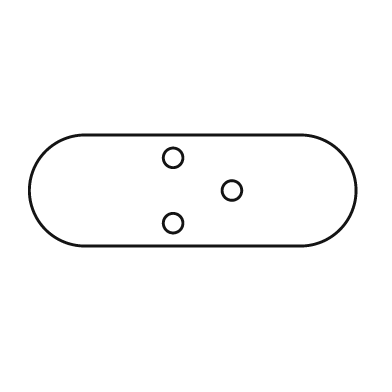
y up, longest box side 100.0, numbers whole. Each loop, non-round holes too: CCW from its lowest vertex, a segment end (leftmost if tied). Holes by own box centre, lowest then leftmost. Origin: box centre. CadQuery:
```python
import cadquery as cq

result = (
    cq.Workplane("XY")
    .moveTo(-33.0, -17.0)
    .lineTo(33.0, -17.0)
    .threePointArc((50.0, 0.0), (33.0, 17.0))
    .lineTo(-33.0, 17.0)
    .threePointArc((-50.0, 0.0), (-33.0, -17.0))
    .close()
    .moveTo(-6.0, -10.0)
    .circle(3.0)
    .moveTo(12.0, 0.0)
    .circle(3.0)
    .moveTo(-6.0, 10.0)
    .circle(3.0)
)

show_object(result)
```